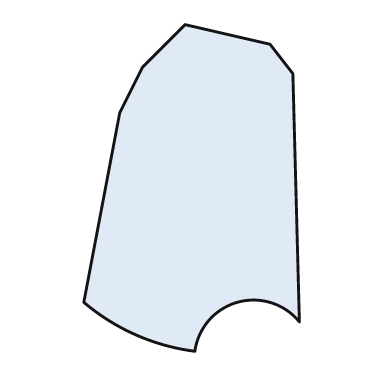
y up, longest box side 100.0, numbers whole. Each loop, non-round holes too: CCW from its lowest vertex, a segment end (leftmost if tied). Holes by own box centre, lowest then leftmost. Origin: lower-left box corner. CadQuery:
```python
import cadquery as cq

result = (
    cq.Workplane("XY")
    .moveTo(34.0, 0.0)
    .threePointArc((47.0, 15.0), (66.0, 9.0))
    .lineTo(64.0, 85.0)
    .lineTo(57.0, 94.0)
    .lineTo(31.0, 100.0)
    .lineTo(18.0, 87.0)
    .lineTo(11.0, 73.0)
    .lineTo(0.0, 15.0)
    .threePointArc((16.0, 5.0), (34.0, 0.0))
    .close()
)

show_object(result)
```